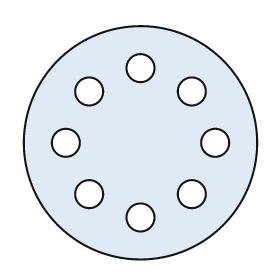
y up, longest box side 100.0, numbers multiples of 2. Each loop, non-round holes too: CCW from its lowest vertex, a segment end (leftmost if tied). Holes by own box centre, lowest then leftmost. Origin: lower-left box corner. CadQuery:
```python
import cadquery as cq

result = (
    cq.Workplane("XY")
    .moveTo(50.0, 50.0)
    .circle(50.0)
    .moveTo(50.0, 18.0)
    .circle(6.0)
    .moveTo(28.0, 28.0)
    .circle(6.0)
    .moveTo(72.0, 28.0)
    .circle(6.0)
    .moveTo(18.0, 50.0)
    .circle(6.0)
    .moveTo(82.0, 50.0)
    .circle(6.0)
    .moveTo(28.0, 72.0)
    .circle(6.0)
    .moveTo(72.0, 72.0)
    .circle(6.0)
    .moveTo(50.0, 82.0)
    .circle(6.0)
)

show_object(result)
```